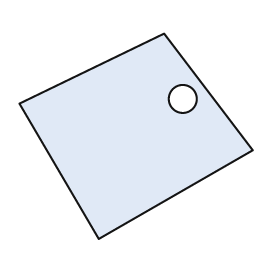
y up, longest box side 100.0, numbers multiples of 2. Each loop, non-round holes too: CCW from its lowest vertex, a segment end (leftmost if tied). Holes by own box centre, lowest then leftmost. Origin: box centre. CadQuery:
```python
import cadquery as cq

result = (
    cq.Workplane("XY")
    .moveTo(-16.0, -44.0)
    .lineTo(50.0, -6.0)
    .lineTo(12.0, 44.0)
    .lineTo(-50.0, 14.0)
    .close()
    .moveTo(20.0, 16.0)
    .circle(6.0)
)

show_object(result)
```